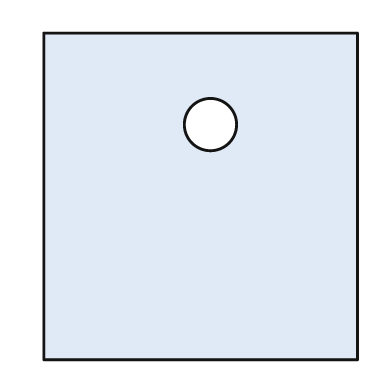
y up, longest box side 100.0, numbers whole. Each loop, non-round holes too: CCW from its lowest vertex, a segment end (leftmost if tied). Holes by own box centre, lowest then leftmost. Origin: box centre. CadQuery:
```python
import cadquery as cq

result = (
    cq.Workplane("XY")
    .moveTo(-48.0, -50.0)
    .lineTo(48.0, -50.0)
    .lineTo(48.0, 50.0)
    .lineTo(-48.0, 50.0)
    .close()
    .moveTo(3.0, 22.0)
    .circle(8.0)
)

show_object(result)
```